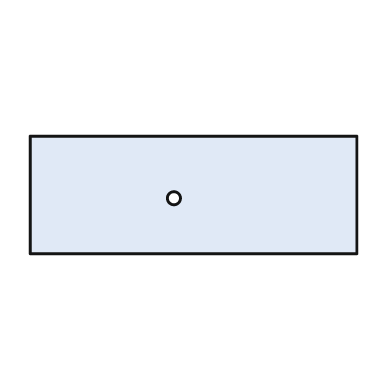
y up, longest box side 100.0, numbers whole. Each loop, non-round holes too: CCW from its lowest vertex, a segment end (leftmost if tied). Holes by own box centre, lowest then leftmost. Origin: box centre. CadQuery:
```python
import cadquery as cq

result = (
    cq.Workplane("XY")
    .moveTo(-50.0, -18.0)
    .lineTo(50.0, -18.0)
    .lineTo(50.0, 18.0)
    .lineTo(-50.0, 18.0)
    .close()
    .moveTo(-6.0, -1.0)
    .circle(2.0)
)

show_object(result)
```